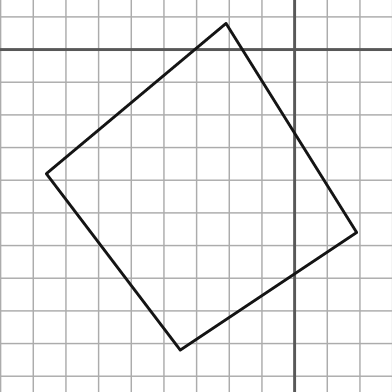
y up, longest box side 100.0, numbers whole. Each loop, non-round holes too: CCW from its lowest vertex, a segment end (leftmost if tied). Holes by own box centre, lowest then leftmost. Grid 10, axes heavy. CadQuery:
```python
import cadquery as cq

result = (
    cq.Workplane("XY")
    .moveTo(-35.0, -92.0)
    .lineTo(19.0, -56.0)
    .lineTo(-21.0, 8.0)
    .lineTo(-76.0, -38.0)
    .close()
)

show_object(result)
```